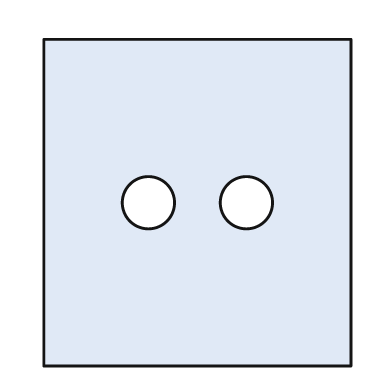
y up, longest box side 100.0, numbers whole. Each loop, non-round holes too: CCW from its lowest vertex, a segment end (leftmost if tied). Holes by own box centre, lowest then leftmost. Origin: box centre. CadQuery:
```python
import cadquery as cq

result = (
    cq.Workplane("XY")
    .moveTo(-47.0, -50.0)
    .lineTo(47.0, -50.0)
    .lineTo(47.0, 50.0)
    .lineTo(-47.0, 50.0)
    .close()
    .moveTo(-15.0, 0.0)
    .circle(8.0)
    .moveTo(15.0, 0.0)
    .circle(8.0)
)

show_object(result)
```